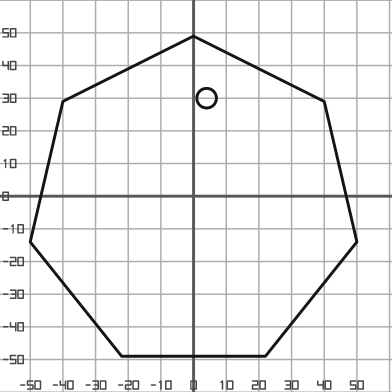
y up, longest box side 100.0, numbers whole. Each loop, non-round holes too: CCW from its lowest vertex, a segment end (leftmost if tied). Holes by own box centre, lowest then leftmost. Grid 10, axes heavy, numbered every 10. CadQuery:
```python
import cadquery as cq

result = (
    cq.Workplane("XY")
    .moveTo(-22.0, -49.0)
    .lineTo(22.0, -49.0)
    .lineTo(50.0, -14.0)
    .lineTo(40.0, 29.0)
    .lineTo(0.0, 49.0)
    .lineTo(-40.0, 29.0)
    .lineTo(-50.0, -14.0)
    .close()
    .moveTo(4.0, 30.0)
    .circle(3.0)
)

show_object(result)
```